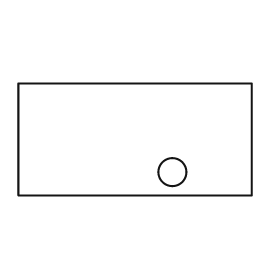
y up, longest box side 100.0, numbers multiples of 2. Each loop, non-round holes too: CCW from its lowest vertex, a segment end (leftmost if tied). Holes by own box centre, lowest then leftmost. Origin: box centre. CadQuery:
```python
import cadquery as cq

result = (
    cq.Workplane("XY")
    .moveTo(-50.0, -24.0)
    .lineTo(50.0, -24.0)
    .lineTo(50.0, 24.0)
    .lineTo(-50.0, 24.0)
    .close()
    .moveTo(16.0, -14.0)
    .circle(6.0)
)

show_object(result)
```